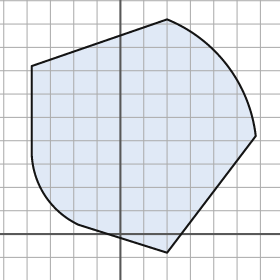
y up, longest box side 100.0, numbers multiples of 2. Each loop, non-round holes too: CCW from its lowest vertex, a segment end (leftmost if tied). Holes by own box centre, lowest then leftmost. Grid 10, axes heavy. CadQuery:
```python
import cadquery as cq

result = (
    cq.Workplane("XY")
    .moveTo(20.0, -8.0)
    .lineTo(58.0, 42.0)
    .threePointArc((46.0, 72.0), (20.0, 92.0))
    .lineTo(-38.0, 72.0)
    .lineTo(-38.0, 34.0)
    .threePointArc((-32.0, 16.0), (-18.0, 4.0))
    .close()
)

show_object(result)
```